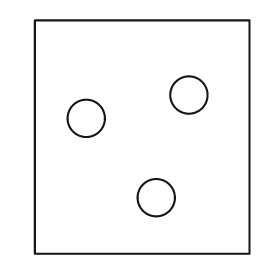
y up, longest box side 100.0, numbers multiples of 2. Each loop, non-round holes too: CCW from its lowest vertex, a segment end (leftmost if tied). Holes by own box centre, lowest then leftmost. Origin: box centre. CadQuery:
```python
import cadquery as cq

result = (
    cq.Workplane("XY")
    .moveTo(-46.0, -50.0)
    .lineTo(46.0, -50.0)
    .lineTo(46.0, 50.0)
    .lineTo(-46.0, 50.0)
    .close()
    .moveTo(6.0, -26.0)
    .circle(8.0)
    .moveTo(-24.0, 8.0)
    .circle(8.0)
    .moveTo(20.0, 18.0)
    .circle(8.0)
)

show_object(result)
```